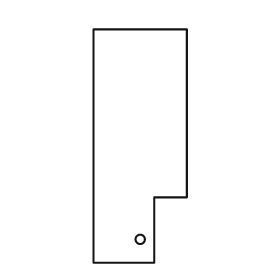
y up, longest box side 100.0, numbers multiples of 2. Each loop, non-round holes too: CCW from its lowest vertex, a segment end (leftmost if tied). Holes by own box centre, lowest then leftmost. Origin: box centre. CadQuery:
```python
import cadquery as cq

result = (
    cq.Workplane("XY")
    .moveTo(-20.0, -50.0)
    .lineTo(6.0, -50.0)
    .lineTo(6.0, -22.0)
    .lineTo(20.0, -22.0)
    .lineTo(20.0, 50.0)
    .lineTo(-20.0, 50.0)
    .close()
    .moveTo(0.0, -40.0)
    .circle(2.0)
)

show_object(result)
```